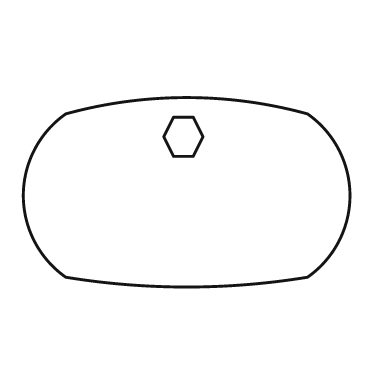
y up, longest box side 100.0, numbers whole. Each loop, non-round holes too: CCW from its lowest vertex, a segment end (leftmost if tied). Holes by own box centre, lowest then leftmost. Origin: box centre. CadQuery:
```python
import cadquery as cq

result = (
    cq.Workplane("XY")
    .moveTo(-37.0, -26.0)
    .threePointArc((0.0, -29.0), (37.0, -26.0))
    .threePointArc((50.0, -1.0), (37.0, 24.0))
    .threePointArc((0.0, 29.0), (-37.0, 24.0))
    .threePointArc((-50.0, -1.0), (-37.0, -26.0))
    .close()
    .moveTo(-4.0, 11.0)
    .lineTo(2.0, 11.0)
    .lineTo(5.0, 17.0)
    .lineTo(2.0, 23.0)
    .lineTo(-4.0, 23.0)
    .lineTo(-7.0, 17.0)
    .close()
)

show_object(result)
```